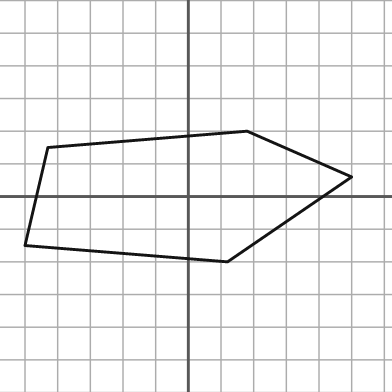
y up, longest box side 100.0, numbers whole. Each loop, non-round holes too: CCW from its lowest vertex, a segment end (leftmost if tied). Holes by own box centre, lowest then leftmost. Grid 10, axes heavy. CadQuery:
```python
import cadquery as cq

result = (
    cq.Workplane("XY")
    .moveTo(12.0, -20.0)
    .lineTo(50.0, 6.0)
    .lineTo(18.0, 20.0)
    .lineTo(-43.0, 15.0)
    .lineTo(-50.0, -15.0)
    .close()
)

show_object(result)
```